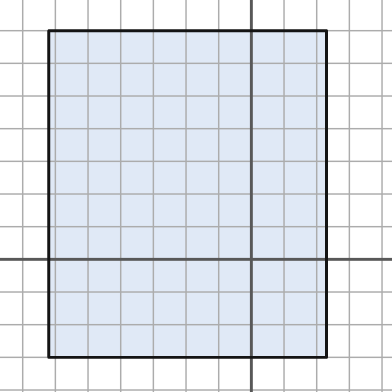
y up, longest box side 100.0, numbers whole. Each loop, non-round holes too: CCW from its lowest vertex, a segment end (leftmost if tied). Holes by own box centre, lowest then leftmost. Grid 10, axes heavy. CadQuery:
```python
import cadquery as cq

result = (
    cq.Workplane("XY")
    .moveTo(-62.0, -30.0)
    .lineTo(23.0, -30.0)
    .lineTo(23.0, 70.0)
    .lineTo(-62.0, 70.0)
    .close()
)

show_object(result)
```